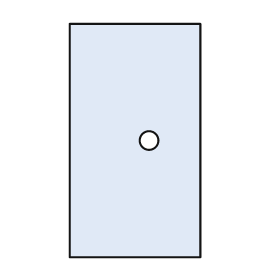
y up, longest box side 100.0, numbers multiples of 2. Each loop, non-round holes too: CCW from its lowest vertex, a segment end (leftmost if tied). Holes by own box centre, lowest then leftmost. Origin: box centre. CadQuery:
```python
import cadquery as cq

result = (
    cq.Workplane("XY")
    .moveTo(-28.0, -50.0)
    .lineTo(28.0, -50.0)
    .lineTo(28.0, 50.0)
    .lineTo(-28.0, 50.0)
    .close()
    .moveTo(6.0, 0.0)
    .circle(4.0)
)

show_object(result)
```